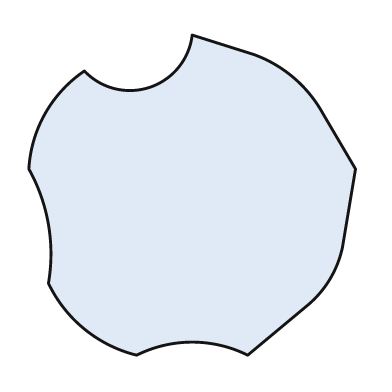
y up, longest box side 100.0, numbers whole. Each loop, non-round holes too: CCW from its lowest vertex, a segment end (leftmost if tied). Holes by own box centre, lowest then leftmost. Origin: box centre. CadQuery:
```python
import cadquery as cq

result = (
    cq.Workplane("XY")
    .moveTo(-17.0, -49.0)
    .threePointArc((0.0, -45.0), (17.0, -49.0))
    .lineTo(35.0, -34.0)
    .threePointArc((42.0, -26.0), (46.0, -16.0))
    .lineTo(50.0, 8.0)
    .lineTo(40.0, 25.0)
    .threePointArc((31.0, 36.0), (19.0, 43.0))
    .lineTo(0.0, 49.0)
    .threePointArc((-13.0, 33.0), (-33.0, 38.0))
    .threePointArc((-45.0, 25.0), (-50.0, 8.0))
    .threePointArc((-44.0, -9.0), (-44.0, -27.0))
    .threePointArc((-33.0, -41.0), (-17.0, -49.0))
    .close()
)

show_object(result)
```